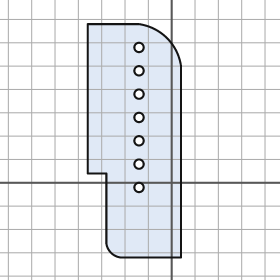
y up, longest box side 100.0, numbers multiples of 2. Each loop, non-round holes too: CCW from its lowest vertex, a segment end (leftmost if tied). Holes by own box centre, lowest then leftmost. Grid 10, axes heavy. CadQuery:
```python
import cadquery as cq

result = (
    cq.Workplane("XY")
    .moveTo(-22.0, -32.0)
    .lineTo(4.0, -32.0)
    .lineTo(4.0, 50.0)
    .threePointArc((-2.0, 62.0), (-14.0, 68.0))
    .lineTo(-36.0, 68.0)
    .lineTo(-36.0, 4.0)
    .lineTo(-28.0, 4.0)
    .lineTo(-28.0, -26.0)
    .threePointArc((-26.0, -30.0), (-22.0, -32.0))
    .close()
    .moveTo(-14.0, -2.0)
    .circle(2.0)
    .moveTo(-14.0, 8.0)
    .circle(2.0)
    .moveTo(-14.0, 18.0)
    .circle(2.0)
    .moveTo(-14.0, 28.0)
    .circle(2.0)
    .moveTo(-14.0, 38.0)
    .circle(2.0)
    .moveTo(-14.0, 48.0)
    .circle(2.0)
    .moveTo(-14.0, 58.0)
    .circle(2.0)
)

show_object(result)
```